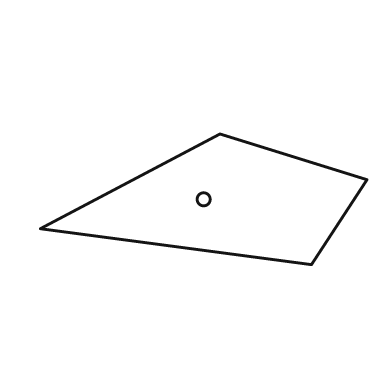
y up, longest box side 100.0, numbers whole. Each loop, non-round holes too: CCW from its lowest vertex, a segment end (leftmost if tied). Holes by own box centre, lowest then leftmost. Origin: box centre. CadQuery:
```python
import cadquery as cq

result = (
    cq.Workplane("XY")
    .moveTo(33.0, -20.0)
    .lineTo(50.0, 6.0)
    .lineTo(5.0, 20.0)
    .lineTo(-50.0, -9.0)
    .close()
    .moveTo(0.0, 0.0)
    .circle(2.0)
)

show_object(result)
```